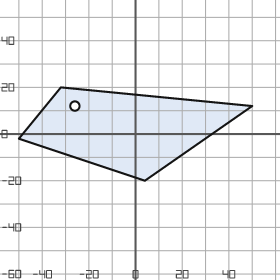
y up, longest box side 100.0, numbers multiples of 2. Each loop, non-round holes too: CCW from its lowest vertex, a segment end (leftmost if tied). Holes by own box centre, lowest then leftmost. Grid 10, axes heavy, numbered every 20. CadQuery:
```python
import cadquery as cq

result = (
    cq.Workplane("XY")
    .moveTo(4.0, -20.0)
    .lineTo(50.0, 12.0)
    .lineTo(-32.0, 20.0)
    .lineTo(-50.0, -2.0)
    .close()
    .moveTo(-26.0, 12.0)
    .circle(2.0)
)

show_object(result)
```